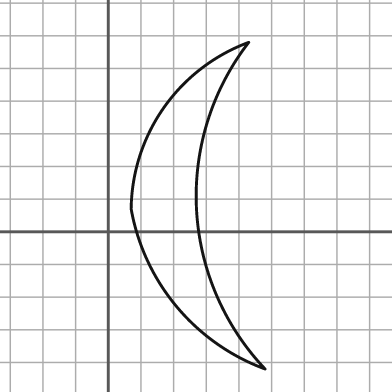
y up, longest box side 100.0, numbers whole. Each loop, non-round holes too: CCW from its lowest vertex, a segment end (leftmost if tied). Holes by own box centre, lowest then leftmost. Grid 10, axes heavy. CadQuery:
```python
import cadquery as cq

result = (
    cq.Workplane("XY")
    .moveTo(48.0, -42.0)
    .threePointArc((27.0, 7.0), (43.0, 58.0))
    .threePointArc((17.0, 38.0), (7.0, 7.0))
    .threePointArc((21.0, -23.0), (48.0, -42.0))
    .close()
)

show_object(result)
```